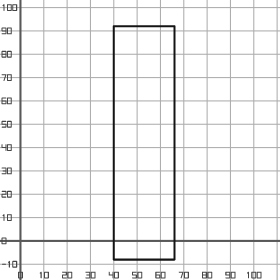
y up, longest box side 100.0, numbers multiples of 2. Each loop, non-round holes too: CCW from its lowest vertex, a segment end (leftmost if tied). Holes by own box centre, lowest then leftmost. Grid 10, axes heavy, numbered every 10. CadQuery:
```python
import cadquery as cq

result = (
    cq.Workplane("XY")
    .moveTo(40.0, -8.0)
    .lineTo(66.0, -8.0)
    .lineTo(66.0, 92.0)
    .lineTo(40.0, 92.0)
    .close()
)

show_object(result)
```